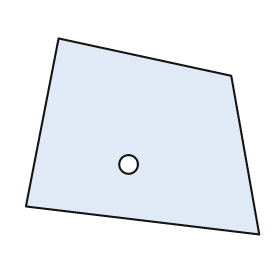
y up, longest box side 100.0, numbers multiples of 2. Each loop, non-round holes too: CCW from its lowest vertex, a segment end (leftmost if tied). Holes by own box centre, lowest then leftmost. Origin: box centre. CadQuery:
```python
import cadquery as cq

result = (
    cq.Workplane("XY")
    .moveTo(50.0, -42.0)
    .lineTo(38.0, 26.0)
    .lineTo(-36.0, 42.0)
    .lineTo(-50.0, -30.0)
    .close()
    .moveTo(-6.0, -12.0)
    .circle(4.0)
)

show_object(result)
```